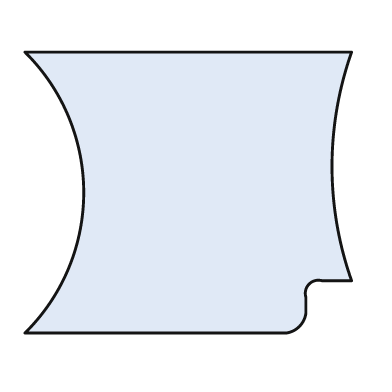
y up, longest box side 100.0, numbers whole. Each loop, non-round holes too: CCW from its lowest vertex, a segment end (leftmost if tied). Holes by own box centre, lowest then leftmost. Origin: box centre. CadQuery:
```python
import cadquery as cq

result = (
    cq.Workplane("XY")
    .moveTo(-50.0, -43.0)
    .lineTo(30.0, -43.0)
    .threePointArc((34.0, -41.0), (36.0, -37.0))
    .lineTo(36.0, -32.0)
    .threePointArc((37.0, -28.0), (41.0, -27.0))
    .lineTo(50.0, -27.0)
    .threePointArc((44.0, 8.0), (50.0, 43.0))
    .lineTo(-50.0, 43.0)
    .threePointArc((-32.0, 0.0), (-50.0, -43.0))
    .close()
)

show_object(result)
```